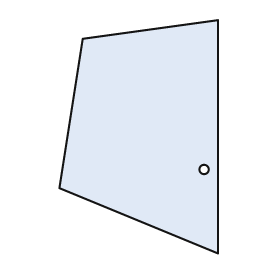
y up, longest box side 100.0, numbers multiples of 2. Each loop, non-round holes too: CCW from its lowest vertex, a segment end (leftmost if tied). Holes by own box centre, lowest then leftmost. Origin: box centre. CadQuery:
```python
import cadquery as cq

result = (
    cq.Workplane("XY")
    .moveTo(34.0, -50.0)
    .lineTo(34.0, 50.0)
    .lineTo(-24.0, 42.0)
    .lineTo(-34.0, -22.0)
    .close()
    .moveTo(28.0, -14.0)
    .circle(2.0)
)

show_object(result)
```